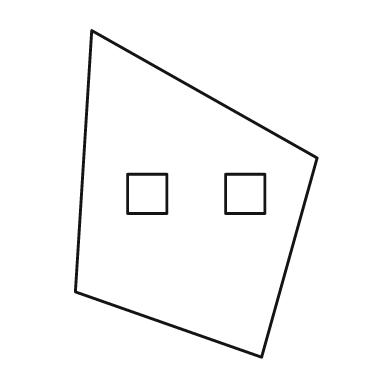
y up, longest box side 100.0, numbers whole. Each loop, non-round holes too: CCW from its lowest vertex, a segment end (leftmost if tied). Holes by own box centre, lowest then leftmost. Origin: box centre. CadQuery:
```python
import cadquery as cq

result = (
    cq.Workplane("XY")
    .moveTo(20.0, -50.0)
    .lineTo(37.0, 11.0)
    .lineTo(-32.0, 50.0)
    .lineTo(-37.0, -30.0)
    .close()
    .moveTo(-21.0, -6.0)
    .lineTo(-9.0, -6.0)
    .lineTo(-9.0, 6.0)
    .lineTo(-21.0, 6.0)
    .close()
    .moveTo(9.0, -6.0)
    .lineTo(21.0, -6.0)
    .lineTo(21.0, 6.0)
    .lineTo(9.0, 6.0)
    .close()
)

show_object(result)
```